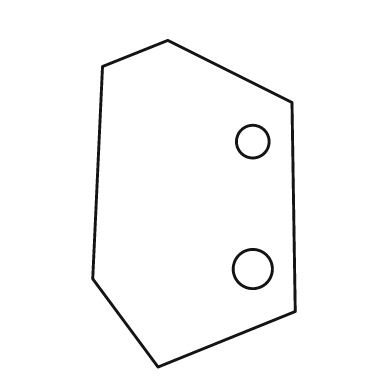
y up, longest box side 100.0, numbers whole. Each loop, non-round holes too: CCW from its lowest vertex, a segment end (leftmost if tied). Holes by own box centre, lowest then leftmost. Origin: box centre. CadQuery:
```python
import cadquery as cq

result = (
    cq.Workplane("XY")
    .moveTo(-11.0, -50.0)
    .lineTo(31.0, -33.0)
    .lineTo(30.0, 31.0)
    .lineTo(-8.0, 50.0)
    .lineTo(-28.0, 42.0)
    .lineTo(-31.0, -23.0)
    .close()
    .moveTo(18.0, -20.0)
    .circle(6.0)
    .moveTo(18.0, 19.0)
    .circle(5.0)
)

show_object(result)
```